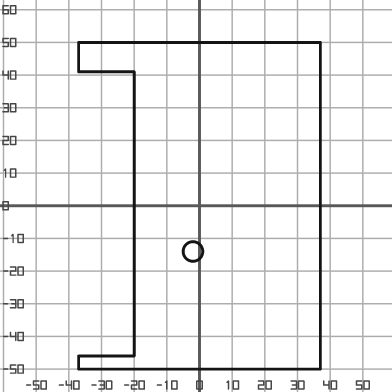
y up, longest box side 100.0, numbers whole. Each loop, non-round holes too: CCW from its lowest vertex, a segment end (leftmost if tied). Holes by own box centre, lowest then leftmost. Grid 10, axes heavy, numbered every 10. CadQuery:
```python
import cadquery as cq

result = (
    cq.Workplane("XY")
    .moveTo(-37.0, -50.0)
    .lineTo(37.0, -50.0)
    .lineTo(37.0, 50.0)
    .lineTo(-37.0, 50.0)
    .lineTo(-37.0, 41.0)
    .lineTo(-20.0, 41.0)
    .lineTo(-20.0, -46.0)
    .lineTo(-37.0, -46.0)
    .close()
    .moveTo(-2.0, -14.0)
    .circle(3.0)
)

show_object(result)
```